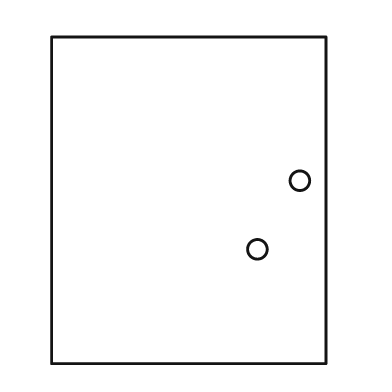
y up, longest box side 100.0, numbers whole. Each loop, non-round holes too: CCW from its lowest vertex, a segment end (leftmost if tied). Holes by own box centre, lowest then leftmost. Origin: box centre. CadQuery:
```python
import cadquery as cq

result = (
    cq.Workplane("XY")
    .moveTo(-42.0, -50.0)
    .lineTo(42.0, -50.0)
    .lineTo(42.0, 50.0)
    .lineTo(-42.0, 50.0)
    .close()
    .moveTo(21.0, -15.0)
    .circle(3.0)
    .moveTo(34.0, 6.0)
    .circle(3.0)
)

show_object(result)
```